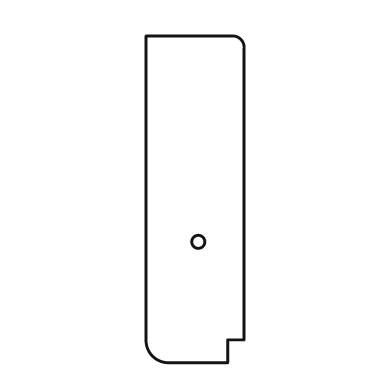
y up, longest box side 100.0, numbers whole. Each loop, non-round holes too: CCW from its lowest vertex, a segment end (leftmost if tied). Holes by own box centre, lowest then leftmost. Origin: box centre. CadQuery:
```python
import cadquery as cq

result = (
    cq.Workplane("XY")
    .moveTo(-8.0, -50.0)
    .lineTo(10.0, -50.0)
    .lineTo(10.0, -43.0)
    .lineTo(15.0, -43.0)
    .lineTo(15.0, 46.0)
    .threePointArc((14.0, 49.0), (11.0, 50.0))
    .lineTo(-15.0, 50.0)
    .lineTo(-15.0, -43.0)
    .threePointArc((-13.0, -48.0), (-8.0, -50.0))
    .close()
    .moveTo(1.0, -13.0)
    .circle(2.0)
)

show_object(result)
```